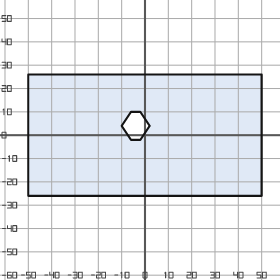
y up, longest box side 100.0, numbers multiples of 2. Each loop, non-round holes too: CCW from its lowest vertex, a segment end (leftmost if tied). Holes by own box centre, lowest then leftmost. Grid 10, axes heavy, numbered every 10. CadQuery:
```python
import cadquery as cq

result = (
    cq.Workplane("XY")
    .moveTo(-50.0, -26.0)
    .lineTo(50.0, -26.0)
    .lineTo(50.0, 26.0)
    .lineTo(-50.0, 26.0)
    .close()
    .moveTo(-6.0, -2.0)
    .lineTo(-2.0, -2.0)
    .lineTo(2.0, 4.0)
    .lineTo(-2.0, 10.0)
    .lineTo(-6.0, 10.0)
    .lineTo(-10.0, 4.0)
    .close()
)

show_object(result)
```